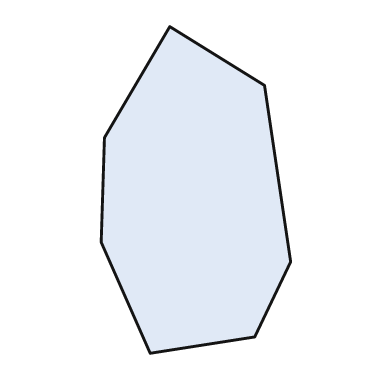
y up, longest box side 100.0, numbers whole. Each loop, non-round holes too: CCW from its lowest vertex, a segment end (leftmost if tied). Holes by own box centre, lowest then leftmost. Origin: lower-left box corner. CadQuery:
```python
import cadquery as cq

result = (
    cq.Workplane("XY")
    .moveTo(15.0, 0.0)
    .lineTo(47.0, 5.0)
    .lineTo(58.0, 28.0)
    .lineTo(50.0, 82.0)
    .lineTo(21.0, 100.0)
    .lineTo(1.0, 66.0)
    .lineTo(0.0, 34.0)
    .close()
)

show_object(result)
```